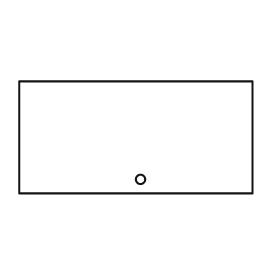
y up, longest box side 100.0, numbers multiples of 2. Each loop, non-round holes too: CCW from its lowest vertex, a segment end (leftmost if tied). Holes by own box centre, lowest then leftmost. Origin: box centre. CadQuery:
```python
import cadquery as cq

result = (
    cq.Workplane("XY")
    .moveTo(-50.0, -24.0)
    .lineTo(50.0, -24.0)
    .lineTo(50.0, 24.0)
    .lineTo(-50.0, 24.0)
    .close()
    .moveTo(2.0, -18.0)
    .circle(2.0)
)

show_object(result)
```